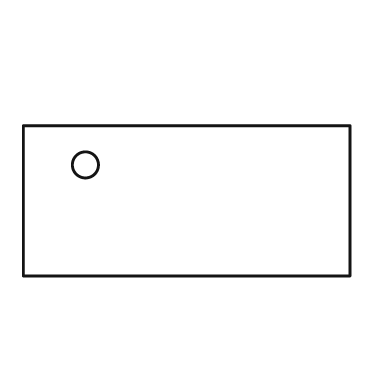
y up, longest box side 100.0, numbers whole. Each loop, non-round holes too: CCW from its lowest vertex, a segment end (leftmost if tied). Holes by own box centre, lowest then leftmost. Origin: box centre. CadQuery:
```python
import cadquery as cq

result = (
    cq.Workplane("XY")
    .moveTo(-50.0, -23.0)
    .lineTo(50.0, -23.0)
    .lineTo(50.0, 23.0)
    .lineTo(-50.0, 23.0)
    .close()
    .moveTo(-31.0, 11.0)
    .circle(4.0)
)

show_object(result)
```